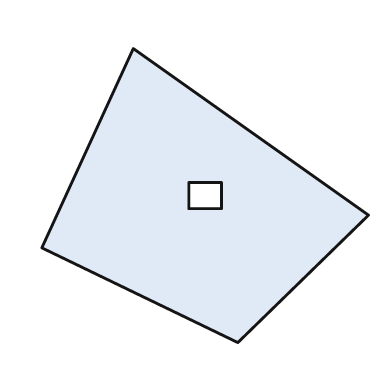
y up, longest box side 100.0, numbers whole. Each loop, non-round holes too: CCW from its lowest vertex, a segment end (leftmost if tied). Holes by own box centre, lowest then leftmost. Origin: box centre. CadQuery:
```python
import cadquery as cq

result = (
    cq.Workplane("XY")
    .moveTo(10.0, -45.0)
    .lineTo(50.0, -6.0)
    .lineTo(-22.0, 45.0)
    .lineTo(-50.0, -16.0)
    .close()
    .moveTo(-5.0, -4.0)
    .lineTo(5.0, -4.0)
    .lineTo(5.0, 4.0)
    .lineTo(-5.0, 4.0)
    .close()
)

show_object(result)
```